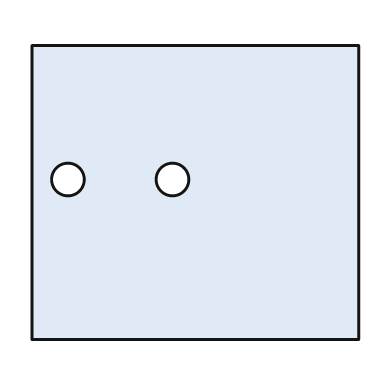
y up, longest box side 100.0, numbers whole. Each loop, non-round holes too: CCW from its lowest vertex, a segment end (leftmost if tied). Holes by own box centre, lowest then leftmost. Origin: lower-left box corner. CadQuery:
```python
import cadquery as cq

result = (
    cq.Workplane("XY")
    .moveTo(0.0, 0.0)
    .lineTo(100.0, 0.0)
    .lineTo(100.0, 90.0)
    .lineTo(0.0, 90.0)
    .close()
    .moveTo(11.0, 49.0)
    .circle(5.0)
    .moveTo(43.0, 49.0)
    .circle(5.0)
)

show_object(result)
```